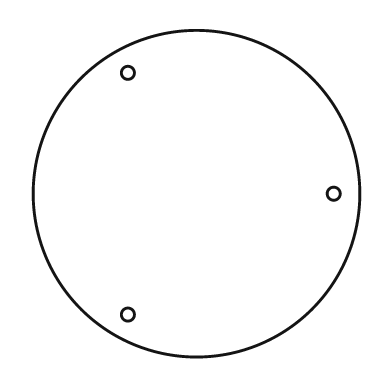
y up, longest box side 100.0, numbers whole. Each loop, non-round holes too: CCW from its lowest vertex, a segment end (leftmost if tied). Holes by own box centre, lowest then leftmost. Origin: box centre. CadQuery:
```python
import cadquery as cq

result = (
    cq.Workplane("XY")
    .moveTo(0.0, 0.0)
    .circle(50.0)
    .moveTo(-21.0, -37.0)
    .circle(2.0)
    .moveTo(42.0, 0.0)
    .circle(2.0)
    .moveTo(-21.0, 37.0)
    .circle(2.0)
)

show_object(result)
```